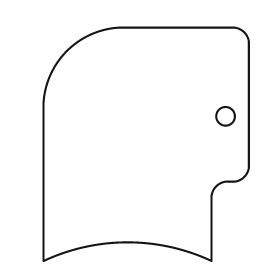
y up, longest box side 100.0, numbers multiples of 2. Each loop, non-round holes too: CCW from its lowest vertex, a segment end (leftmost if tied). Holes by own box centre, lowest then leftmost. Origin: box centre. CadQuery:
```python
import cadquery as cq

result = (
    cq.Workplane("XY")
    .moveTo(-44.0, -50.0)
    .threePointArc((-8.0, -42.0), (28.0, -50.0))
    .lineTo(28.0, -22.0)
    .threePointArc((30.0, -18.0), (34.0, -16.0))
    .lineTo(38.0, -16.0)
    .threePointArc((42.0, -14.0), (44.0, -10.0))
    .lineTo(44.0, 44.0)
    .threePointArc((42.0, 48.0), (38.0, 50.0))
    .lineTo(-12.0, 50.0)
    .threePointArc((-34.0, 40.0), (-44.0, 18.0))
    .close()
    .moveTo(34.0, 12.0)
    .circle(4.0)
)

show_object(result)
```